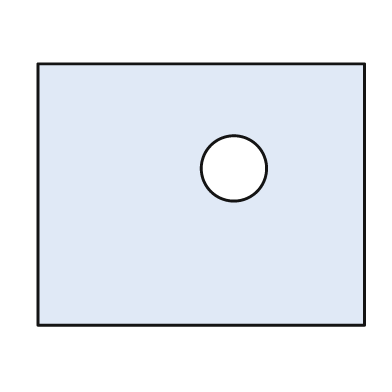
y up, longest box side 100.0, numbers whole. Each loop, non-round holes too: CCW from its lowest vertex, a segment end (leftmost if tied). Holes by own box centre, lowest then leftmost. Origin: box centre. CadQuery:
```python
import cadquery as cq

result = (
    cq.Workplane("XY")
    .moveTo(-50.0, -40.0)
    .lineTo(50.0, -40.0)
    .lineTo(50.0, 40.0)
    .lineTo(-50.0, 40.0)
    .close()
    .moveTo(10.0, 8.0)
    .circle(10.0)
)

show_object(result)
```